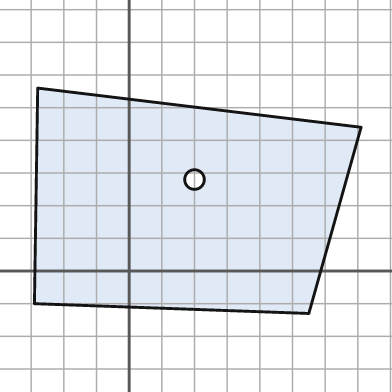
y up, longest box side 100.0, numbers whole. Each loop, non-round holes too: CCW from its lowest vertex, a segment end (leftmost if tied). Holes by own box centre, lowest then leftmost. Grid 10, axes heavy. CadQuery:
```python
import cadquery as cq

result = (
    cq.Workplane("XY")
    .moveTo(55.0, -13.0)
    .lineTo(71.0, 44.0)
    .lineTo(-28.0, 56.0)
    .lineTo(-29.0, -10.0)
    .close()
    .moveTo(20.0, 28.0)
    .circle(3.0)
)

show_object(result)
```